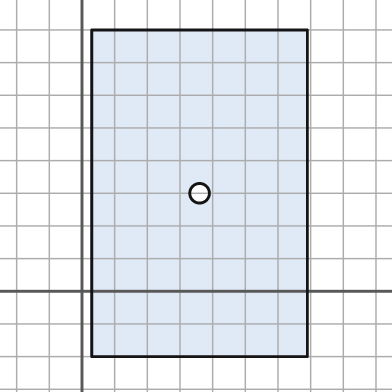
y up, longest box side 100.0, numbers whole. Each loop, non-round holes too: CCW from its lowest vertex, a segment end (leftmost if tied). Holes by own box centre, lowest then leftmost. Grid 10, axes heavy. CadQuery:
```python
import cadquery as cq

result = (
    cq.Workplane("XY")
    .moveTo(3.0, -20.0)
    .lineTo(69.0, -20.0)
    .lineTo(69.0, 80.0)
    .lineTo(3.0, 80.0)
    .close()
    .moveTo(36.0, 30.0)
    .circle(3.0)
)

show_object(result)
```